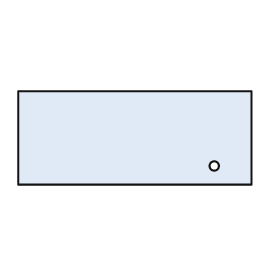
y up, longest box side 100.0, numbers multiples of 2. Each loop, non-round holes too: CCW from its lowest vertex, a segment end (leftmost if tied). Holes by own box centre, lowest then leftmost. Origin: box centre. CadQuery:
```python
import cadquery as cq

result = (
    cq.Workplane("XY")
    .moveTo(-50.0, -20.0)
    .lineTo(50.0, -20.0)
    .lineTo(50.0, 20.0)
    .lineTo(-50.0, 20.0)
    .close()
    .moveTo(34.0, -12.0)
    .circle(2.0)
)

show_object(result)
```